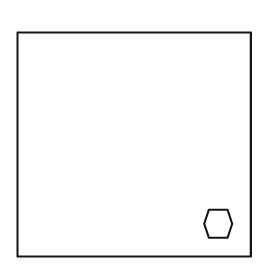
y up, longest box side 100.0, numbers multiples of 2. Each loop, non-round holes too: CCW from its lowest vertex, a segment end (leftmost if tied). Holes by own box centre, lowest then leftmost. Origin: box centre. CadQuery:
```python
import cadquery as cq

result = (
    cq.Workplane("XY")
    .moveTo(-50.0, -48.0)
    .lineTo(50.0, -48.0)
    .lineTo(50.0, 48.0)
    .lineTo(-50.0, 48.0)
    .close()
    .moveTo(32.0, -40.0)
    .lineTo(40.0, -40.0)
    .lineTo(42.0, -34.0)
    .lineTo(40.0, -28.0)
    .lineTo(32.0, -28.0)
    .lineTo(30.0, -34.0)
    .close()
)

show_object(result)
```